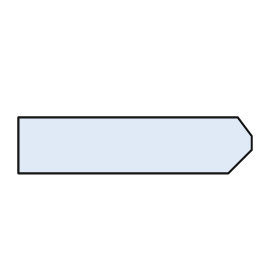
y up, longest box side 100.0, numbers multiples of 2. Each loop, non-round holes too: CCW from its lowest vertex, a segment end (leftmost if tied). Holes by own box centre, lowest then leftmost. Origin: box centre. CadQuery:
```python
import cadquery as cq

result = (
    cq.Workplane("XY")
    .moveTo(-50.0, -12.0)
    .lineTo(40.0, -12.0)
    .lineTo(50.0, -2.0)
    .lineTo(50.0, 4.0)
    .lineTo(44.0, 12.0)
    .lineTo(-50.0, 12.0)
    .close()
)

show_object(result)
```